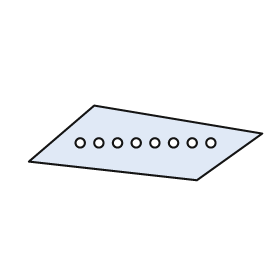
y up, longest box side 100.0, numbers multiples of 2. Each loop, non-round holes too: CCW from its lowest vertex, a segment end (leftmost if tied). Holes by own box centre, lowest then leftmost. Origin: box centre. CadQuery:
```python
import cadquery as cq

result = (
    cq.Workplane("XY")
    .moveTo(22.0, -16.0)
    .lineTo(50.0, 4.0)
    .lineTo(-22.0, 16.0)
    .lineTo(-50.0, -8.0)
    .close()
    .moveTo(-28.0, 0.0)
    .circle(2.0)
    .moveTo(-20.0, 0.0)
    .circle(2.0)
    .moveTo(-12.0, 0.0)
    .circle(2.0)
    .moveTo(-4.0, 0.0)
    .circle(2.0)
    .moveTo(4.0, 0.0)
    .circle(2.0)
    .moveTo(12.0, 0.0)
    .circle(2.0)
    .moveTo(20.0, 0.0)
    .circle(2.0)
    .moveTo(28.0, 0.0)
    .circle(2.0)
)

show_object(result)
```